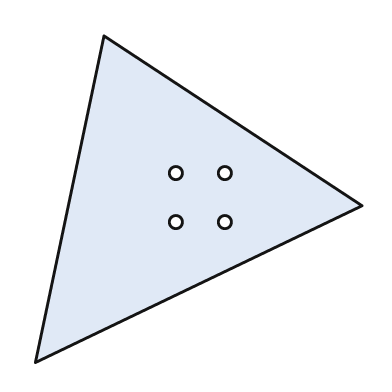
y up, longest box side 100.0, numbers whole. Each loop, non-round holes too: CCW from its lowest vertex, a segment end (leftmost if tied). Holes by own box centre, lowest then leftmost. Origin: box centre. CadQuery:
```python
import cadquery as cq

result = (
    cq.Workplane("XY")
    .moveTo(-50.0, -50.0)
    .lineTo(50.0, -2.0)
    .lineTo(-29.0, 50.0)
    .close()
    .moveTo(-7.0, -7.0)
    .circle(2.0)
    .moveTo(8.0, -7.0)
    .circle(2.0)
    .moveTo(-7.0, 8.0)
    .circle(2.0)
    .moveTo(8.0, 8.0)
    .circle(2.0)
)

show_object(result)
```